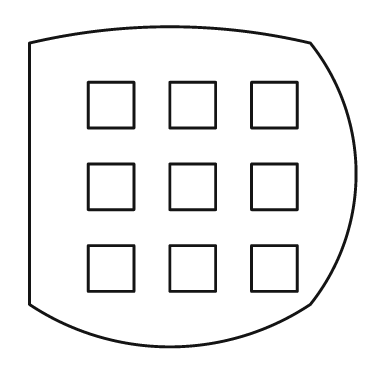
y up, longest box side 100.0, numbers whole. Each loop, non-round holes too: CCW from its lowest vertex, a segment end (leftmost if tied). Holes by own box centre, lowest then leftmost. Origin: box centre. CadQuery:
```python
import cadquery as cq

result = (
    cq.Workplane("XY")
    .moveTo(-50.0, -36.0)
    .threePointArc((-7.0, -49.0), (36.0, -36.0))
    .threePointArc((50.0, 4.0), (36.0, 44.0))
    .threePointArc((-7.0, 49.0), (-50.0, 44.0))
    .close()
    .moveTo(-32.0, -32.0)
    .lineTo(-18.0, -32.0)
    .lineTo(-18.0, -18.0)
    .lineTo(-32.0, -18.0)
    .close()
    .moveTo(-7.0, -32.0)
    .lineTo(7.0, -32.0)
    .lineTo(7.0, -18.0)
    .lineTo(-7.0, -18.0)
    .close()
    .moveTo(18.0, -32.0)
    .lineTo(32.0, -32.0)
    .lineTo(32.0, -18.0)
    .lineTo(18.0, -18.0)
    .close()
    .moveTo(-32.0, -7.0)
    .lineTo(-18.0, -7.0)
    .lineTo(-18.0, 7.0)
    .lineTo(-32.0, 7.0)
    .close()
    .moveTo(-7.0, -7.0)
    .lineTo(7.0, -7.0)
    .lineTo(7.0, 7.0)
    .lineTo(-7.0, 7.0)
    .close()
    .moveTo(18.0, -7.0)
    .lineTo(32.0, -7.0)
    .lineTo(32.0, 7.0)
    .lineTo(18.0, 7.0)
    .close()
    .moveTo(-32.0, 18.0)
    .lineTo(-18.0, 18.0)
    .lineTo(-18.0, 32.0)
    .lineTo(-32.0, 32.0)
    .close()
    .moveTo(-7.0, 18.0)
    .lineTo(7.0, 18.0)
    .lineTo(7.0, 32.0)
    .lineTo(-7.0, 32.0)
    .close()
    .moveTo(18.0, 18.0)
    .lineTo(32.0, 18.0)
    .lineTo(32.0, 32.0)
    .lineTo(18.0, 32.0)
    .close()
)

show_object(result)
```